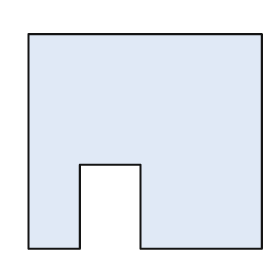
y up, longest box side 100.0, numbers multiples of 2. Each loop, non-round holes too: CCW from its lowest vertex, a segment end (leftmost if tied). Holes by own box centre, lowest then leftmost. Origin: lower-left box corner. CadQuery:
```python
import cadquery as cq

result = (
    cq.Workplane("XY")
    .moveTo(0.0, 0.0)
    .lineTo(22.0, 0.0)
    .lineTo(22.0, 36.0)
    .lineTo(48.0, 36.0)
    .lineTo(48.0, 0.0)
    .lineTo(100.0, 0.0)
    .lineTo(100.0, 92.0)
    .lineTo(0.0, 92.0)
    .close()
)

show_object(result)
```